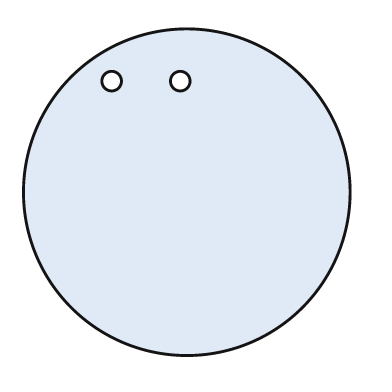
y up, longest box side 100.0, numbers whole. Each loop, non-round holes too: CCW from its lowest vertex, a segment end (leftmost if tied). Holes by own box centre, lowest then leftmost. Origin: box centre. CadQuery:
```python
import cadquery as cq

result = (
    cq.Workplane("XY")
    .moveTo(0.0, 0.0)
    .circle(50.0)
    .moveTo(-23.0, 34.0)
    .circle(3.0)
    .moveTo(-2.0, 34.0)
    .circle(3.0)
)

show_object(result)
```